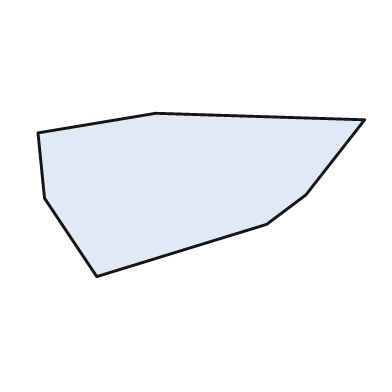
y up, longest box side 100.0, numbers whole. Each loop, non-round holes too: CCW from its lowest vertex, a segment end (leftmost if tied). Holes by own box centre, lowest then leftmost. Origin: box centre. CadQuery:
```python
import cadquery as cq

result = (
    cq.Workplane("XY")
    .moveTo(-32.0, -25.0)
    .lineTo(20.0, -9.0)
    .lineTo(32.0, 0.0)
    .lineTo(50.0, 23.0)
    .lineTo(-14.0, 25.0)
    .lineTo(-50.0, 19.0)
    .lineTo(-48.0, -1.0)
    .close()
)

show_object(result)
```